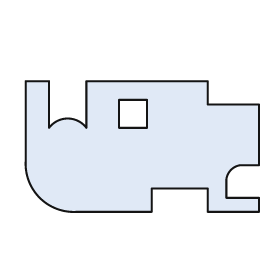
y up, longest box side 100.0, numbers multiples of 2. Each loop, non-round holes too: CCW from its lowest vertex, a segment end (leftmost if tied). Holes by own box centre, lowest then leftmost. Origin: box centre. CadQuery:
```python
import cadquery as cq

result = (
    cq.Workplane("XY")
    .moveTo(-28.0, -28.0)
    .lineTo(4.0, -28.0)
    .lineTo(4.0, -18.0)
    .lineTo(28.0, -18.0)
    .lineTo(28.0, -28.0)
    .lineTo(50.0, -28.0)
    .lineTo(50.0, -22.0)
    .lineTo(36.0, -22.0)
    .lineTo(36.0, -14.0)
    .threePointArc((38.0, -10.0), (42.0, -8.0))
    .lineTo(50.0, -8.0)
    .lineTo(50.0, 18.0)
    .lineTo(28.0, 18.0)
    .lineTo(28.0, 28.0)
    .lineTo(-24.0, 28.0)
    .lineTo(-24.0, 8.0)
    .threePointArc((-32.0, 12.0), (-40.0, 8.0))
    .lineTo(-40.0, 28.0)
    .lineTo(-50.0, 28.0)
    .lineTo(-50.0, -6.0)
    .threePointArc((-44.0, -22.0), (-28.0, -28.0))
    .close()
    .moveTo(-10.0, 8.0)
    .lineTo(2.0, 8.0)
    .lineTo(2.0, 20.0)
    .lineTo(-10.0, 20.0)
    .close()
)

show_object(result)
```